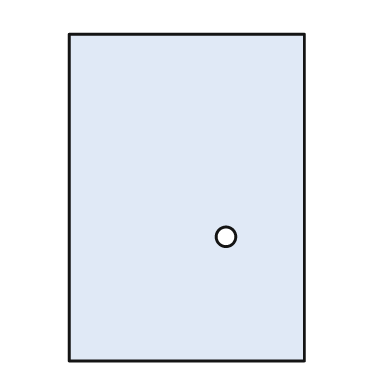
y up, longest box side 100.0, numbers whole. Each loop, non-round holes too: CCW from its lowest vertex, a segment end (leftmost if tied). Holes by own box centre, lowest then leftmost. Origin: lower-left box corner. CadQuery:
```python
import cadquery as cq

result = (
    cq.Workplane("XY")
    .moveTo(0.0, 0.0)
    .lineTo(72.0, 0.0)
    .lineTo(72.0, 100.0)
    .lineTo(0.0, 100.0)
    .close()
    .moveTo(48.0, 38.0)
    .circle(3.0)
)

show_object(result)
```